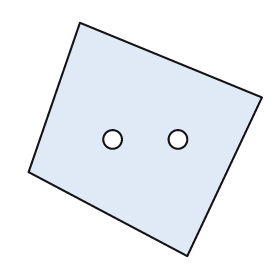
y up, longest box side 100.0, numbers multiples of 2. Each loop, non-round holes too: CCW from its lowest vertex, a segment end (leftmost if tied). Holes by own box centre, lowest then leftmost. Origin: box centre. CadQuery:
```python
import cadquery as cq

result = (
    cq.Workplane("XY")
    .moveTo(18.0, -50.0)
    .lineTo(50.0, 18.0)
    .lineTo(-28.0, 50.0)
    .lineTo(-50.0, -14.0)
    .close()
    .moveTo(-14.0, 0.0)
    .circle(4.0)
    .moveTo(14.0, 0.0)
    .circle(4.0)
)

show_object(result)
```